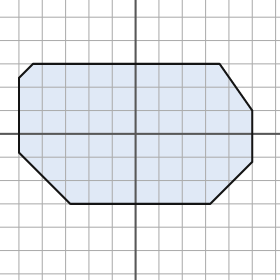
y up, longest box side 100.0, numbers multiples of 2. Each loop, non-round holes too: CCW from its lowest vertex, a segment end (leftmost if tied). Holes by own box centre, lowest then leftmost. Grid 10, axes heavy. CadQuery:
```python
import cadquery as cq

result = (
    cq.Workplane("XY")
    .moveTo(-28.0, -30.0)
    .lineTo(32.0, -30.0)
    .lineTo(50.0, -12.0)
    .lineTo(50.0, 10.0)
    .lineTo(36.0, 30.0)
    .lineTo(-44.0, 30.0)
    .lineTo(-50.0, 24.0)
    .lineTo(-50.0, -8.0)
    .close()
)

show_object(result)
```